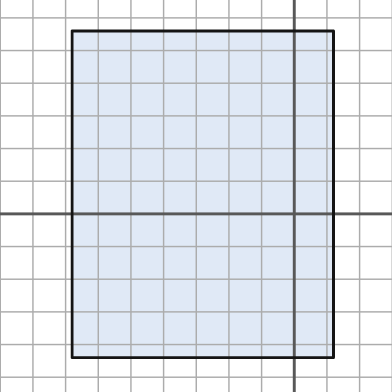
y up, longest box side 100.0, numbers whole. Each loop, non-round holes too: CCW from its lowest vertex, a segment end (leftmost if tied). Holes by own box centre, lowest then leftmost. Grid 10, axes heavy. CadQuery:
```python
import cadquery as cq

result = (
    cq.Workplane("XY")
    .moveTo(-68.0, -44.0)
    .lineTo(12.0, -44.0)
    .lineTo(12.0, 56.0)
    .lineTo(-68.0, 56.0)
    .close()
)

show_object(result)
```